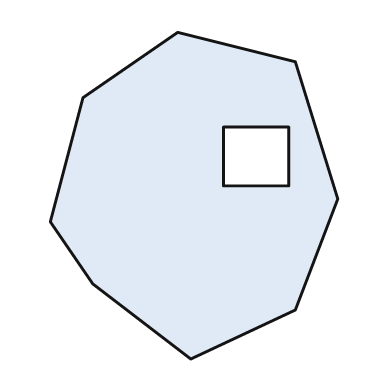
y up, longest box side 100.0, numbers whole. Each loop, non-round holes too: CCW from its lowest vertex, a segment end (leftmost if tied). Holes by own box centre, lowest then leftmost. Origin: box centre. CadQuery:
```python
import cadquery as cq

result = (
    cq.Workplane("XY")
    .moveTo(-1.0, -50.0)
    .lineTo(31.0, -35.0)
    .lineTo(44.0, -1.0)
    .lineTo(31.0, 41.0)
    .lineTo(-5.0, 50.0)
    .lineTo(-34.0, 30.0)
    .lineTo(-44.0, -8.0)
    .lineTo(-31.0, -27.0)
    .close()
    .moveTo(9.0, 3.0)
    .lineTo(29.0, 3.0)
    .lineTo(29.0, 21.0)
    .lineTo(9.0, 21.0)
    .close()
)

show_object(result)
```